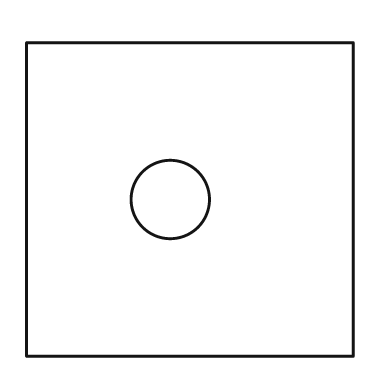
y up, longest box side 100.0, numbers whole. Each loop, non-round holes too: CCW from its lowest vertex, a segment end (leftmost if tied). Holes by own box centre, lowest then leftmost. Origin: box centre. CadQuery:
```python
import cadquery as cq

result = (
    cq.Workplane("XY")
    .moveTo(-50.0, -48.0)
    .lineTo(50.0, -48.0)
    .lineTo(50.0, 48.0)
    .lineTo(-50.0, 48.0)
    .close()
    .moveTo(-6.0, 0.0)
    .circle(12.0)
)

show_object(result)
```